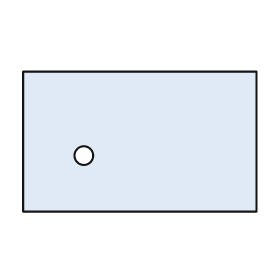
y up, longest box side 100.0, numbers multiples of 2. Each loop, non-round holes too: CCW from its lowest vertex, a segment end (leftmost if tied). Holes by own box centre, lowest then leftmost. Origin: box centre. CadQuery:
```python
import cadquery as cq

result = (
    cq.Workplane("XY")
    .moveTo(-50.0, -30.0)
    .lineTo(50.0, -30.0)
    .lineTo(50.0, 30.0)
    .lineTo(-50.0, 30.0)
    .close()
    .moveTo(-24.0, -6.0)
    .circle(4.0)
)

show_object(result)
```